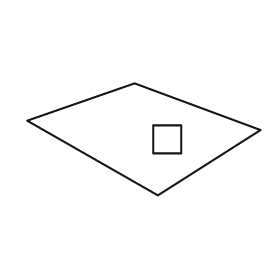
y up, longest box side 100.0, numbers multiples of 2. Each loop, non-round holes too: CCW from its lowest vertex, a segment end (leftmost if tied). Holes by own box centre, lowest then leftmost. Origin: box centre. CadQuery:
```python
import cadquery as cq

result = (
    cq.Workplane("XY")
    .moveTo(6.0, -24.0)
    .lineTo(50.0, 4.0)
    .lineTo(-4.0, 24.0)
    .lineTo(-50.0, 8.0)
    .close()
    .moveTo(4.0, -6.0)
    .lineTo(16.0, -6.0)
    .lineTo(16.0, 6.0)
    .lineTo(4.0, 6.0)
    .close()
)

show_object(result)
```